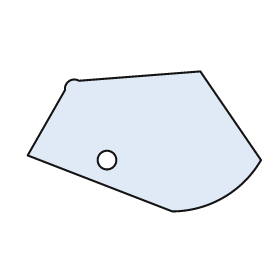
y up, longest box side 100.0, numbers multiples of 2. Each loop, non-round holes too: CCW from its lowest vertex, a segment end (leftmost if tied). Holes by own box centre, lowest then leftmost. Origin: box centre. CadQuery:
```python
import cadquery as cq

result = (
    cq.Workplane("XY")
    .moveTo(12.0, -30.0)
    .threePointArc((34.0, -24.0), (50.0, -8.0))
    .lineTo(24.0, 30.0)
    .lineTo(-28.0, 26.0)
    .threePointArc((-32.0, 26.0), (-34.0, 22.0))
    .lineTo(-50.0, -6.0)
    .close()
    .moveTo(-16.0, -8.0)
    .circle(4.0)
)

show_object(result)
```